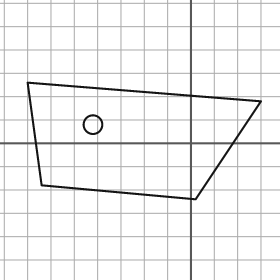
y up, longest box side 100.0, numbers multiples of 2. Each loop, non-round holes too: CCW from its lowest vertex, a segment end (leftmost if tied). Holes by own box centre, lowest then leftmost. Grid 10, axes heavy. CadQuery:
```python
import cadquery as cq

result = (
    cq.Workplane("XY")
    .moveTo(2.0, -24.0)
    .lineTo(30.0, 18.0)
    .lineTo(-70.0, 26.0)
    .lineTo(-64.0, -18.0)
    .close()
    .moveTo(-42.0, 8.0)
    .circle(4.0)
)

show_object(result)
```